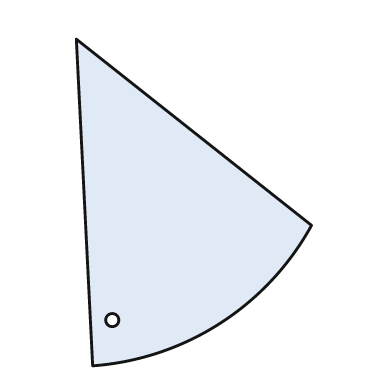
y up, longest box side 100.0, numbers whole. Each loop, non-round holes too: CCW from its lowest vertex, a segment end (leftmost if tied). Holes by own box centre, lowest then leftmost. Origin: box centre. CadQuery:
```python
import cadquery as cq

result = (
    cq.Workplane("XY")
    .moveTo(-31.0, -50.0)
    .threePointArc((8.0, -37.0), (36.0, -7.0))
    .lineTo(-36.0, 50.0)
    .close()
    .moveTo(-25.0, -36.0)
    .circle(2.0)
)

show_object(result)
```